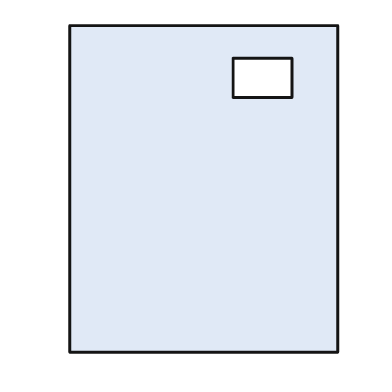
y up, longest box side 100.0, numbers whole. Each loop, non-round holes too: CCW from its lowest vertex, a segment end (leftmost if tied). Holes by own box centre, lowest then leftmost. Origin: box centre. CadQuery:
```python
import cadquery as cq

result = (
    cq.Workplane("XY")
    .moveTo(-41.0, -50.0)
    .lineTo(41.0, -50.0)
    .lineTo(41.0, 50.0)
    .lineTo(-41.0, 50.0)
    .close()
    .moveTo(9.0, 28.0)
    .lineTo(27.0, 28.0)
    .lineTo(27.0, 40.0)
    .lineTo(9.0, 40.0)
    .close()
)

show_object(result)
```